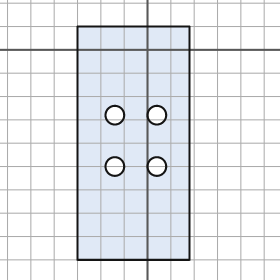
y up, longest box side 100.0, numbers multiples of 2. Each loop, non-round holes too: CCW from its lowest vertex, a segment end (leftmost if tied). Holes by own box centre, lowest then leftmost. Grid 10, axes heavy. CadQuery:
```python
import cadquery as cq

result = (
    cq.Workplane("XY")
    .moveTo(-30.0, -90.0)
    .lineTo(18.0, -90.0)
    .lineTo(18.0, 10.0)
    .lineTo(-30.0, 10.0)
    .close()
    .moveTo(-14.0, -50.0)
    .circle(4.0)
    .moveTo(4.0, -50.0)
    .circle(4.0)
    .moveTo(-14.0, -28.0)
    .circle(4.0)
    .moveTo(4.0, -28.0)
    .circle(4.0)
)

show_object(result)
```